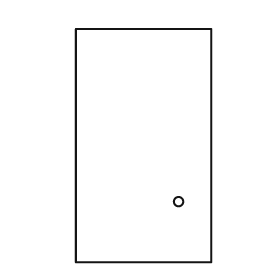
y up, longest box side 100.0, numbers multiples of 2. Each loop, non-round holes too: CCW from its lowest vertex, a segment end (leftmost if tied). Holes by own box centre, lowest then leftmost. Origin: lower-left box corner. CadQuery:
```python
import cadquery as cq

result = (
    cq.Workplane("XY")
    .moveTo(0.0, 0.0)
    .lineTo(58.0, 0.0)
    .lineTo(58.0, 100.0)
    .lineTo(0.0, 100.0)
    .close()
    .moveTo(44.0, 26.0)
    .circle(2.0)
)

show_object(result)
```